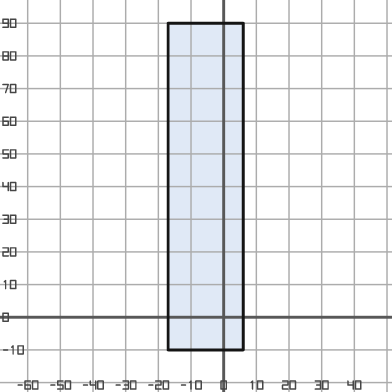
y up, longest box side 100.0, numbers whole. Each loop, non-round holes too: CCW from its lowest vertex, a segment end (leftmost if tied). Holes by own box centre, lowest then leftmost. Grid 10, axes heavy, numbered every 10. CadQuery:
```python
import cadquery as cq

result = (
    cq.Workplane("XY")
    .moveTo(-17.0, -10.0)
    .lineTo(6.0, -10.0)
    .lineTo(6.0, 90.0)
    .lineTo(-17.0, 90.0)
    .close()
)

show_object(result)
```